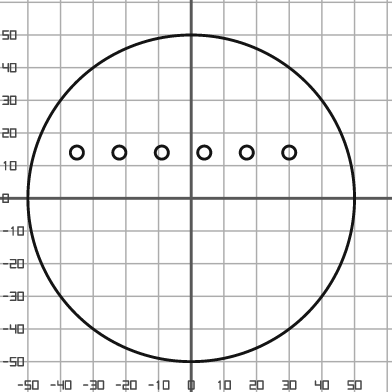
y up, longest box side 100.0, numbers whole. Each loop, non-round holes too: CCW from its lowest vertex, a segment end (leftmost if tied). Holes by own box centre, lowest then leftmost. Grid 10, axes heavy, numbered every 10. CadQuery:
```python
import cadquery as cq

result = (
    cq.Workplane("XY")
    .moveTo(0.0, 0.0)
    .circle(50.0)
    .moveTo(-35.0, 14.0)
    .circle(2.0)
    .moveTo(-22.0, 14.0)
    .circle(2.0)
    .moveTo(-9.0, 14.0)
    .circle(2.0)
    .moveTo(4.0, 14.0)
    .circle(2.0)
    .moveTo(17.0, 14.0)
    .circle(2.0)
    .moveTo(30.0, 14.0)
    .circle(2.0)
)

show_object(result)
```